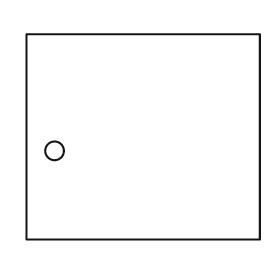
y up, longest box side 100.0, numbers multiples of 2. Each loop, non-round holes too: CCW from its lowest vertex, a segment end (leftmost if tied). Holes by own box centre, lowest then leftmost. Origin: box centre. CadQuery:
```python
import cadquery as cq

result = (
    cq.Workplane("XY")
    .moveTo(-50.0, -44.0)
    .lineTo(50.0, -44.0)
    .lineTo(50.0, 44.0)
    .lineTo(-50.0, 44.0)
    .close()
    .moveTo(-38.0, -6.0)
    .circle(4.0)
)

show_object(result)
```